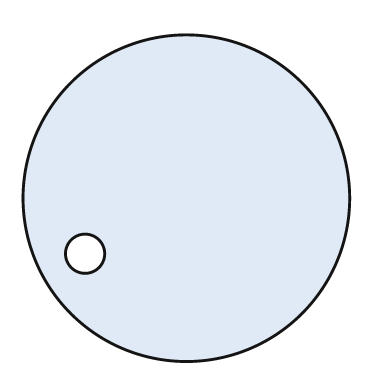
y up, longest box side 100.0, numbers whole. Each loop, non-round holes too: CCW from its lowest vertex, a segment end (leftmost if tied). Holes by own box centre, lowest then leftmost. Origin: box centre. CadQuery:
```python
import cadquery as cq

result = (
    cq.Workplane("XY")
    .moveTo(0.0, 0.0)
    .circle(50.0)
    .moveTo(-31.0, -17.0)
    .circle(6.0)
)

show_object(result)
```